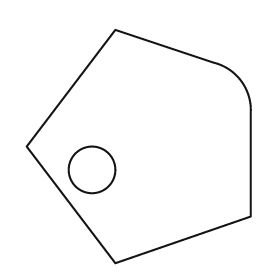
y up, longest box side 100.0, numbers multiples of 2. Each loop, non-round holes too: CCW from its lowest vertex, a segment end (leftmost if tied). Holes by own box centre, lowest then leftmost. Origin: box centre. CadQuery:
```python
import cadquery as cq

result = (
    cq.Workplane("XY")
    .moveTo(-10.0, -50.0)
    .lineTo(48.0, -30.0)
    .lineTo(48.0, 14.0)
    .threePointArc((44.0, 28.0), (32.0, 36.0))
    .lineTo(-10.0, 50.0)
    .lineTo(-48.0, 0.0)
    .close()
    .moveTo(-20.0, -10.0)
    .circle(10.0)
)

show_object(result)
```